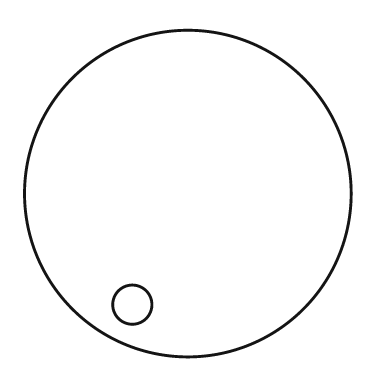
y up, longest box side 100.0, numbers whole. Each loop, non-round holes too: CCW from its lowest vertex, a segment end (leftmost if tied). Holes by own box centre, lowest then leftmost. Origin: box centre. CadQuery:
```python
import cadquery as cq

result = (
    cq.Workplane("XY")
    .moveTo(0.0, 0.0)
    .circle(50.0)
    .moveTo(-17.0, -34.0)
    .circle(6.0)
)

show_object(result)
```